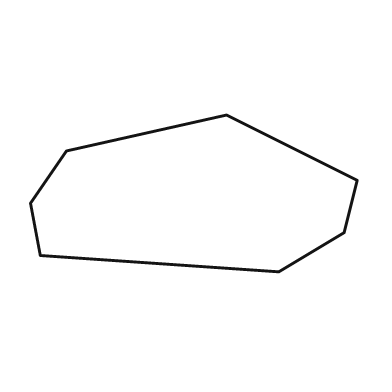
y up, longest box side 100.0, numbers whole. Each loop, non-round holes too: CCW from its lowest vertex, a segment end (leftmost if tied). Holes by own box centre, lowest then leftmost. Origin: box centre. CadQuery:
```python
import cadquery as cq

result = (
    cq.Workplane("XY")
    .moveTo(26.0, -24.0)
    .lineTo(46.0, -12.0)
    .lineTo(50.0, 4.0)
    .lineTo(10.0, 24.0)
    .lineTo(-39.0, 13.0)
    .lineTo(-50.0, -3.0)
    .lineTo(-47.0, -19.0)
    .close()
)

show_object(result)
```